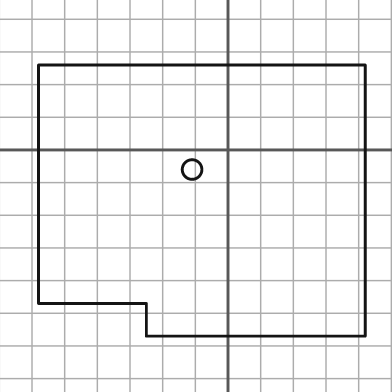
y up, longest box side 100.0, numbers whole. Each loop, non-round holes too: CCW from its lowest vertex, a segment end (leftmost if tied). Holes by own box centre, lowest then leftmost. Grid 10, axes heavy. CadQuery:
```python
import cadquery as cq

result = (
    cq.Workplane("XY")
    .moveTo(-25.0, -57.0)
    .lineTo(42.0, -57.0)
    .lineTo(42.0, 26.0)
    .lineTo(-58.0, 26.0)
    .lineTo(-58.0, -47.0)
    .lineTo(-25.0, -47.0)
    .close()
    .moveTo(-11.0, -6.0)
    .circle(3.0)
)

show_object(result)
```